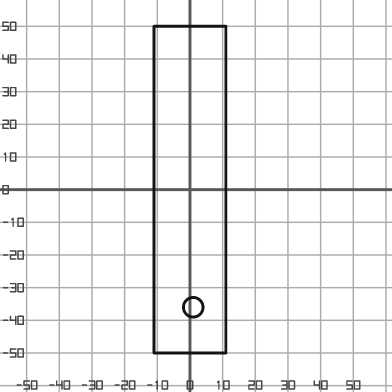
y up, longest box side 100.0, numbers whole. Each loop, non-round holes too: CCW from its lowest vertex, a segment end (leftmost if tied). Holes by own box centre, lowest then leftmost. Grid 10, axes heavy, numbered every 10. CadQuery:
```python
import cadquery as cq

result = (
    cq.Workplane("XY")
    .moveTo(-11.0, -50.0)
    .lineTo(11.0, -50.0)
    .lineTo(11.0, 50.0)
    .lineTo(-11.0, 50.0)
    .close()
    .moveTo(1.0, -36.0)
    .circle(3.0)
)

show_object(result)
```